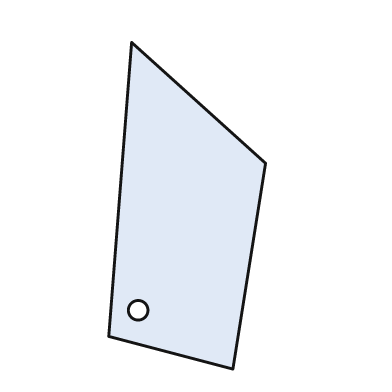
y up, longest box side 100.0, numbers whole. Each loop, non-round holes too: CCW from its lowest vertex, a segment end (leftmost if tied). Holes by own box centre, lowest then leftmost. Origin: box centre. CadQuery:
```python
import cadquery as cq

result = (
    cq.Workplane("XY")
    .moveTo(14.0, -50.0)
    .lineTo(24.0, 13.0)
    .lineTo(-17.0, 50.0)
    .lineTo(-24.0, -40.0)
    .close()
    .moveTo(-15.0, -32.0)
    .circle(3.0)
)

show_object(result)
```